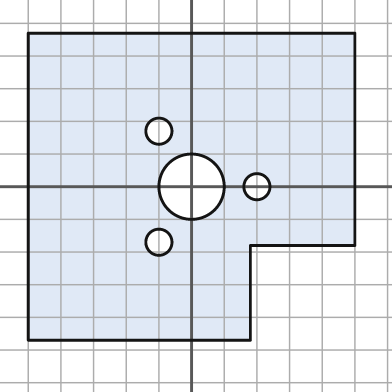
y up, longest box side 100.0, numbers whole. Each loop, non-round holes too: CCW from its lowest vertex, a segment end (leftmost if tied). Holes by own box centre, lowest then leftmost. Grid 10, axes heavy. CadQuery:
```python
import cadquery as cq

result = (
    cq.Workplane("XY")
    .moveTo(-50.0, -47.0)
    .lineTo(18.0, -47.0)
    .lineTo(18.0, -18.0)
    .lineTo(50.0, -18.0)
    .lineTo(50.0, 47.0)
    .lineTo(-50.0, 47.0)
    .close()
    .moveTo(-10.0, -17.0)
    .circle(4.0)
    .moveTo(0.0, 0.0)
    .circle(10.0)
    .moveTo(20.0, 0.0)
    .circle(4.0)
    .moveTo(-10.0, 17.0)
    .circle(4.0)
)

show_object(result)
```